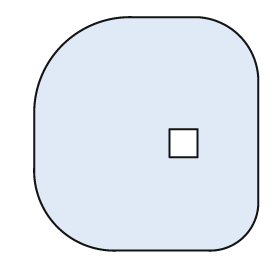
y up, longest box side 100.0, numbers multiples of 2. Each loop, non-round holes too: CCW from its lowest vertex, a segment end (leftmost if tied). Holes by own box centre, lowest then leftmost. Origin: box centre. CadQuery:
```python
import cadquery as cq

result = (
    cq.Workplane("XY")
    .moveTo(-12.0, -50.0)
    .lineTo(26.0, -50.0)
    .threePointArc((42.0, -44.0), (48.0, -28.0))
    .lineTo(48.0, 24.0)
    .threePointArc((40.0, 42.0), (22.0, 50.0))
    .lineTo(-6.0, 50.0)
    .threePointArc((-36.0, 38.0), (-48.0, 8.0))
    .lineTo(-48.0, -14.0)
    .threePointArc((-38.0, -40.0), (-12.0, -50.0))
    .close()
    .moveTo(10.0, -10.0)
    .lineTo(22.0, -10.0)
    .lineTo(22.0, 2.0)
    .lineTo(10.0, 2.0)
    .close()
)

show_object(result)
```